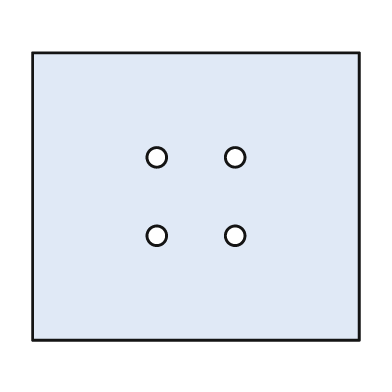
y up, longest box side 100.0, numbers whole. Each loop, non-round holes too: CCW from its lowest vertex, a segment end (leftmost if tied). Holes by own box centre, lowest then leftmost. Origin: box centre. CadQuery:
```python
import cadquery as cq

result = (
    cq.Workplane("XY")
    .moveTo(-50.0, -44.0)
    .lineTo(50.0, -44.0)
    .lineTo(50.0, 44.0)
    .lineTo(-50.0, 44.0)
    .close()
    .moveTo(-12.0, -12.0)
    .circle(3.0)
    .moveTo(12.0, -12.0)
    .circle(3.0)
    .moveTo(-12.0, 12.0)
    .circle(3.0)
    .moveTo(12.0, 12.0)
    .circle(3.0)
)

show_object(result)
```